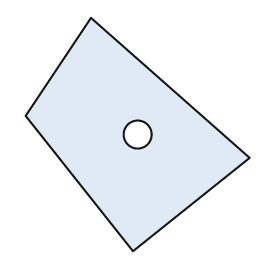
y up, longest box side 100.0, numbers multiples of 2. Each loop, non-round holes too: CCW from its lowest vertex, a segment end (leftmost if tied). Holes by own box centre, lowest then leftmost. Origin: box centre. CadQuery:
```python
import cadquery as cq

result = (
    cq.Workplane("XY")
    .moveTo(-2.0, -50.0)
    .lineTo(48.0, -10.0)
    .lineTo(-20.0, 50.0)
    .lineTo(-48.0, 8.0)
    .close()
    .moveTo(0.0, 0.0)
    .circle(6.0)
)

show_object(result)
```